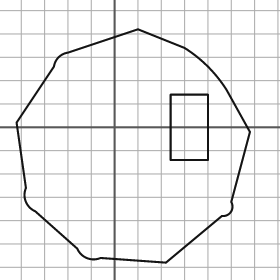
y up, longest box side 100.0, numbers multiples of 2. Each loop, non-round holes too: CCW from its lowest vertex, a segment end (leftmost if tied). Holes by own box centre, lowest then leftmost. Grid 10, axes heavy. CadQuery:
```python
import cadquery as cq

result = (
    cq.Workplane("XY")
    .moveTo(22.0, -58.0)
    .lineTo(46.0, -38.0)
    .threePointArc((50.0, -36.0), (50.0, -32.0))
    .lineTo(58.0, -2.0)
    .lineTo(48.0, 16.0)
    .threePointArc((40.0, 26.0), (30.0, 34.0))
    .lineTo(10.0, 42.0)
    .lineTo(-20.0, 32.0)
    .threePointArc((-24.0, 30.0), (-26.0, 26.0))
    .lineTo(-42.0, 2.0)
    .lineTo(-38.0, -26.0)
    .threePointArc((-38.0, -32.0), (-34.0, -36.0))
    .lineTo(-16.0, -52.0)
    .threePointArc((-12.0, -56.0), (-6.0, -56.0))
    .close()
    .moveTo(24.0, -14.0)
    .lineTo(40.0, -14.0)
    .lineTo(40.0, 14.0)
    .lineTo(24.0, 14.0)
    .close()
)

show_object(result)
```